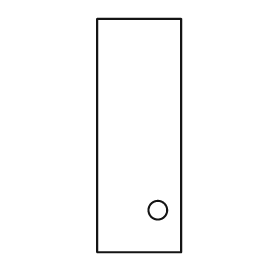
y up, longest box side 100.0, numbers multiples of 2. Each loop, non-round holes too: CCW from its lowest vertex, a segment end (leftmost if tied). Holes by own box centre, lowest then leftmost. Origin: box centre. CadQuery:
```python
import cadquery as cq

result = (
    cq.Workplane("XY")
    .moveTo(-18.0, -50.0)
    .lineTo(18.0, -50.0)
    .lineTo(18.0, 50.0)
    .lineTo(-18.0, 50.0)
    .close()
    .moveTo(8.0, -32.0)
    .circle(4.0)
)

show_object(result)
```